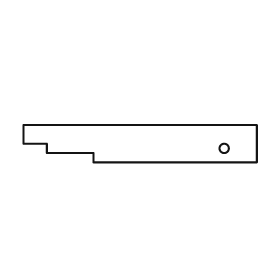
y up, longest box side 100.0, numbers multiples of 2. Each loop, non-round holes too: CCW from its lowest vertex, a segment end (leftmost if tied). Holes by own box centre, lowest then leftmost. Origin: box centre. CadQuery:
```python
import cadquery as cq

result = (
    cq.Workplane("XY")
    .moveTo(-20.0, -8.0)
    .lineTo(50.0, -8.0)
    .lineTo(50.0, 8.0)
    .lineTo(-50.0, 8.0)
    .lineTo(-50.0, 0.0)
    .lineTo(-40.0, 0.0)
    .lineTo(-40.0, -4.0)
    .lineTo(-20.0, -4.0)
    .close()
    .moveTo(36.0, -2.0)
    .circle(2.0)
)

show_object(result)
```